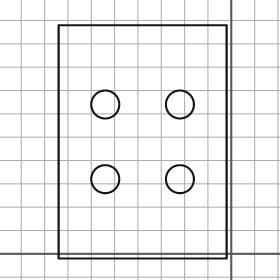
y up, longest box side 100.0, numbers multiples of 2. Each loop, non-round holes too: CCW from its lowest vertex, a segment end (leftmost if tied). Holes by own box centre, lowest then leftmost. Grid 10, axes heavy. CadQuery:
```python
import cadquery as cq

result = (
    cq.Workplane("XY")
    .moveTo(-74.0, -2.0)
    .lineTo(-2.0, -2.0)
    .lineTo(-2.0, 98.0)
    .lineTo(-74.0, 98.0)
    .close()
    .moveTo(-54.0, 32.0)
    .circle(6.0)
    .moveTo(-22.0, 32.0)
    .circle(6.0)
    .moveTo(-54.0, 64.0)
    .circle(6.0)
    .moveTo(-22.0, 64.0)
    .circle(6.0)
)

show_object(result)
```